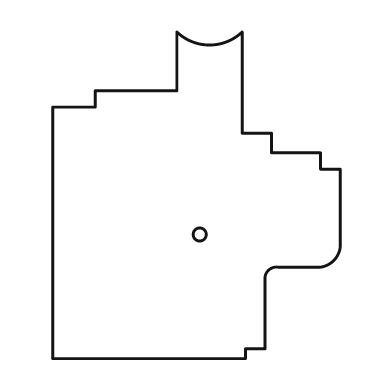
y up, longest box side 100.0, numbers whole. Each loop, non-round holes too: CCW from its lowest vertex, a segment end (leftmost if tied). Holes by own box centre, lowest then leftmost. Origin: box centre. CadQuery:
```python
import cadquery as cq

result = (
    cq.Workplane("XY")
    .moveTo(-44.0, -50.0)
    .lineTo(15.0, -50.0)
    .lineTo(15.0, -47.0)
    .lineTo(21.0, -47.0)
    .lineTo(21.0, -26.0)
    .threePointArc((22.0, -23.0), (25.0, -22.0))
    .lineTo(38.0, -22.0)
    .threePointArc((42.0, -20.0), (44.0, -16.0))
    .lineTo(44.0, 8.0)
    .lineTo(38.0, 8.0)
    .lineTo(38.0, 13.0)
    .lineTo(23.0, 13.0)
    .lineTo(23.0, 19.0)
    .lineTo(14.0, 19.0)
    .lineTo(14.0, 50.0)
    .threePointArc((4.0, 46.0), (-6.0, 50.0))
    .lineTo(-6.0, 32.0)
    .lineTo(-31.0, 32.0)
    .lineTo(-31.0, 27.0)
    .lineTo(-44.0, 27.0)
    .close()
    .moveTo(1.0, -12.0)
    .circle(2.0)
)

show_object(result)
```